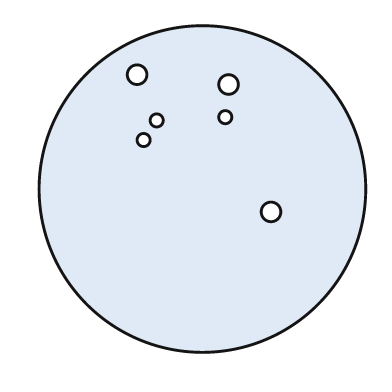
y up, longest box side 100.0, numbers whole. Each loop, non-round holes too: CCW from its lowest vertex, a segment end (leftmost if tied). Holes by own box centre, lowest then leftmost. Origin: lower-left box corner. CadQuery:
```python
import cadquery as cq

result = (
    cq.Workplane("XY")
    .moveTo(50.0, 50.0)
    .circle(50.0)
    .moveTo(71.0, 43.0)
    .circle(3.0)
    .moveTo(32.0, 65.0)
    .circle(2.0)
    .moveTo(36.0, 71.0)
    .circle(2.0)
    .moveTo(57.0, 72.0)
    .circle(2.0)
    .moveTo(58.0, 82.0)
    .circle(3.0)
    .moveTo(30.0, 85.0)
    .circle(3.0)
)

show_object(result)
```